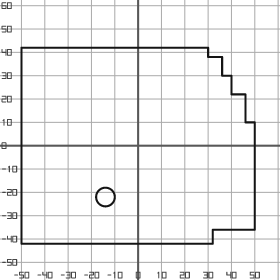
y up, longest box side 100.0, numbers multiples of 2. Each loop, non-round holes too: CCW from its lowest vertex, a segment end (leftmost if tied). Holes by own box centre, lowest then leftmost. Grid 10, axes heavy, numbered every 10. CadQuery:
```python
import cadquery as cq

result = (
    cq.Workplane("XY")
    .moveTo(-50.0, -42.0)
    .lineTo(32.0, -42.0)
    .lineTo(32.0, -36.0)
    .lineTo(50.0, -36.0)
    .lineTo(50.0, 10.0)
    .lineTo(46.0, 10.0)
    .lineTo(46.0, 22.0)
    .lineTo(40.0, 22.0)
    .lineTo(40.0, 30.0)
    .lineTo(36.0, 30.0)
    .lineTo(36.0, 38.0)
    .lineTo(30.0, 38.0)
    .lineTo(30.0, 42.0)
    .lineTo(-50.0, 42.0)
    .close()
    .moveTo(-14.0, -22.0)
    .circle(4.0)
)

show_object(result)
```